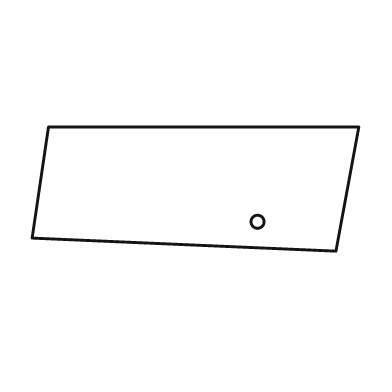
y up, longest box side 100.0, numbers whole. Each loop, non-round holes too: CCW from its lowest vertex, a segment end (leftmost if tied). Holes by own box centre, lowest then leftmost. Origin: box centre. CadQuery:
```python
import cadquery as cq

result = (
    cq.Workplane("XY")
    .moveTo(43.0, -19.0)
    .lineTo(50.0, 19.0)
    .lineTo(-45.0, 19.0)
    .lineTo(-50.0, -15.0)
    .close()
    .moveTo(19.0, -10.0)
    .circle(2.0)
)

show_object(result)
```